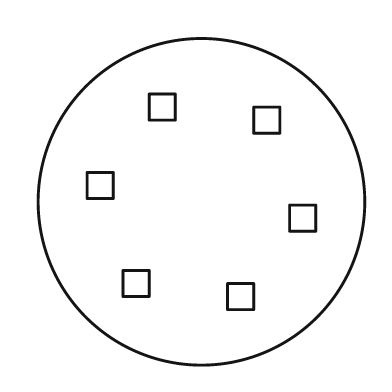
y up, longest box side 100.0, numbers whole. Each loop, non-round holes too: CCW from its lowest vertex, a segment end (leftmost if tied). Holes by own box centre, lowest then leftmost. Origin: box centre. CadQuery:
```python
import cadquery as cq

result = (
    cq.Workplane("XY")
    .moveTo(0.0, 0.0)
    .circle(50.0)
    .moveTo(8.0, -33.0)
    .lineTo(16.0, -33.0)
    .lineTo(16.0, -25.0)
    .lineTo(8.0, -25.0)
    .close()
    .moveTo(-24.0, -29.0)
    .lineTo(-16.0, -29.0)
    .lineTo(-16.0, -21.0)
    .lineTo(-24.0, -21.0)
    .close()
    .moveTo(27.0, -9.0)
    .lineTo(35.0, -9.0)
    .lineTo(35.0, -1.0)
    .lineTo(27.0, -1.0)
    .close()
    .moveTo(-35.0, 1.0)
    .lineTo(-27.0, 1.0)
    .lineTo(-27.0, 9.0)
    .lineTo(-35.0, 9.0)
    .close()
    .moveTo(16.0, 21.0)
    .lineTo(24.0, 21.0)
    .lineTo(24.0, 29.0)
    .lineTo(16.0, 29.0)
    .close()
    .moveTo(-16.0, 25.0)
    .lineTo(-8.0, 25.0)
    .lineTo(-8.0, 33.0)
    .lineTo(-16.0, 33.0)
    .close()
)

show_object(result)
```